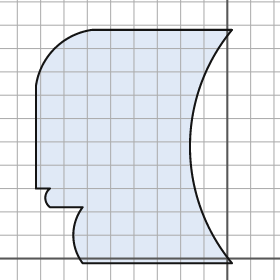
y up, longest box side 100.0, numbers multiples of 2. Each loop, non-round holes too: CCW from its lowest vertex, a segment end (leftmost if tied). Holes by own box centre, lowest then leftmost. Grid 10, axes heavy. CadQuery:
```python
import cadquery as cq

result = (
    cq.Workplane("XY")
    .moveTo(-62.0, -2.0)
    .lineTo(2.0, -2.0)
    .threePointArc((-16.0, 48.0), (2.0, 98.0))
    .lineTo(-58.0, 98.0)
    .threePointArc((-74.0, 90.0), (-82.0, 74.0))
    .lineTo(-82.0, 30.0)
    .lineTo(-76.0, 30.0)
    .threePointArc((-78.0, 26.0), (-76.0, 22.0))
    .lineTo(-62.0, 22.0)
    .threePointArc((-66.0, 10.0), (-62.0, -2.0))
    .close()
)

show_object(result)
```